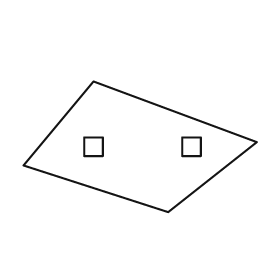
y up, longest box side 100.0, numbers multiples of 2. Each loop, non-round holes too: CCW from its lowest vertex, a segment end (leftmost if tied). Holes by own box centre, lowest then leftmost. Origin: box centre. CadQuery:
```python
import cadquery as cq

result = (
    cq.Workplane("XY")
    .moveTo(12.0, -28.0)
    .lineTo(50.0, 2.0)
    .lineTo(-20.0, 28.0)
    .lineTo(-50.0, -8.0)
    .close()
    .moveTo(-24.0, -4.0)
    .lineTo(-16.0, -4.0)
    .lineTo(-16.0, 4.0)
    .lineTo(-24.0, 4.0)
    .close()
    .moveTo(18.0, -4.0)
    .lineTo(26.0, -4.0)
    .lineTo(26.0, 4.0)
    .lineTo(18.0, 4.0)
    .close()
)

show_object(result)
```